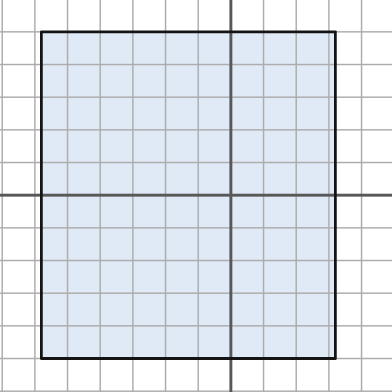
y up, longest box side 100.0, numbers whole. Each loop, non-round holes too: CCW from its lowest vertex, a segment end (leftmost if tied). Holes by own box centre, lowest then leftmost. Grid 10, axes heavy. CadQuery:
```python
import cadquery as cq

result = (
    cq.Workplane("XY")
    .moveTo(-58.0, -50.0)
    .lineTo(32.0, -50.0)
    .lineTo(32.0, 50.0)
    .lineTo(-58.0, 50.0)
    .close()
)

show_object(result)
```